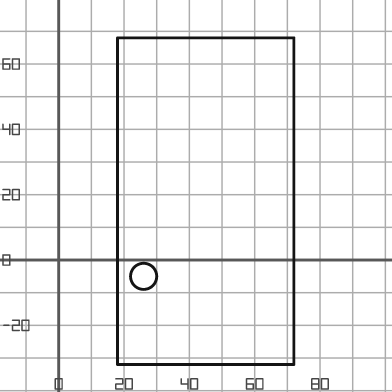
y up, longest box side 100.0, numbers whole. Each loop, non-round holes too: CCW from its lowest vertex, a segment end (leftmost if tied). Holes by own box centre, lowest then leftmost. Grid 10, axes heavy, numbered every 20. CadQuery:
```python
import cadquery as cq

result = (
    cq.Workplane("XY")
    .moveTo(18.0, -32.0)
    .lineTo(72.0, -32.0)
    .lineTo(72.0, 68.0)
    .lineTo(18.0, 68.0)
    .close()
    .moveTo(26.0, -5.0)
    .circle(4.0)
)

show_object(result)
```